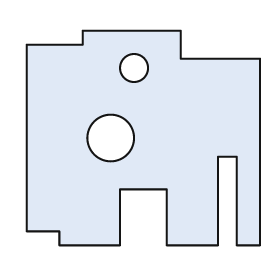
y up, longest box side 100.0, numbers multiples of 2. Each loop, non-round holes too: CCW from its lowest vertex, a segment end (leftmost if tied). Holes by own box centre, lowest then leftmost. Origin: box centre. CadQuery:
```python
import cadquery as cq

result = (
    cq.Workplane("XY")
    .moveTo(-36.0, -46.0)
    .lineTo(-10.0, -46.0)
    .lineTo(-10.0, -22.0)
    .lineTo(10.0, -22.0)
    .lineTo(10.0, -46.0)
    .lineTo(32.0, -46.0)
    .lineTo(32.0, -8.0)
    .lineTo(40.0, -8.0)
    .lineTo(40.0, -46.0)
    .lineTo(50.0, -46.0)
    .lineTo(50.0, 34.0)
    .lineTo(16.0, 34.0)
    .lineTo(16.0, 46.0)
    .lineTo(-26.0, 46.0)
    .lineTo(-26.0, 40.0)
    .lineTo(-50.0, 40.0)
    .lineTo(-50.0, -40.0)
    .lineTo(-36.0, -40.0)
    .close()
    .moveTo(-14.0, 0.0)
    .circle(10.0)
    .moveTo(-4.0, 30.0)
    .circle(6.0)
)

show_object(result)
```